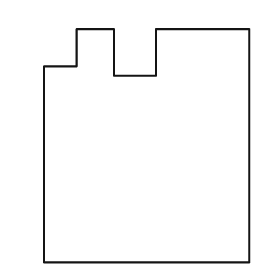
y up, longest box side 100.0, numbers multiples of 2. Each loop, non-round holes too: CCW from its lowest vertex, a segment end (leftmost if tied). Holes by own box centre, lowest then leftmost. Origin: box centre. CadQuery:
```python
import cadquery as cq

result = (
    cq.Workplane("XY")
    .moveTo(-44.0, -50.0)
    .lineTo(44.0, -50.0)
    .lineTo(44.0, 50.0)
    .lineTo(4.0, 50.0)
    .lineTo(4.0, 30.0)
    .lineTo(-14.0, 30.0)
    .lineTo(-14.0, 50.0)
    .lineTo(-30.0, 50.0)
    .lineTo(-30.0, 34.0)
    .lineTo(-44.0, 34.0)
    .close()
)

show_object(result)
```